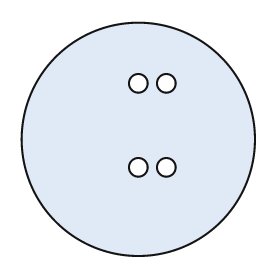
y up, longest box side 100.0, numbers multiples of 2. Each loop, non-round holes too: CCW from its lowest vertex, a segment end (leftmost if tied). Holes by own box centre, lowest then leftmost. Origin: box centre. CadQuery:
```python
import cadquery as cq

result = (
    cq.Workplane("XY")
    .moveTo(0.0, 0.0)
    .circle(50.0)
    .moveTo(0.0, -12.0)
    .circle(4.0)
    .moveTo(12.0, -12.0)
    .circle(4.0)
    .moveTo(0.0, 24.0)
    .circle(4.0)
    .moveTo(12.0, 24.0)
    .circle(4.0)
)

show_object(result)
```